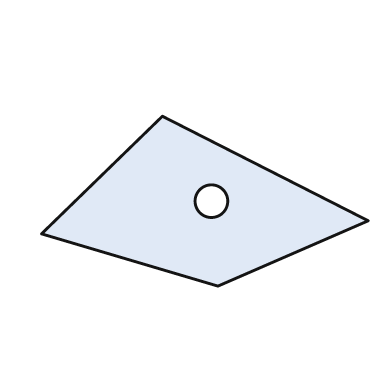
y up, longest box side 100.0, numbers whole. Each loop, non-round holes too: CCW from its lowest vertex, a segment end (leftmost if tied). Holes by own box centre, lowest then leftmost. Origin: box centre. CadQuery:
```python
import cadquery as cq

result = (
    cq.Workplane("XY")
    .moveTo(4.0, -26.0)
    .lineTo(50.0, -6.0)
    .lineTo(-13.0, 26.0)
    .lineTo(-50.0, -10.0)
    .close()
    .moveTo(2.0, 0.0)
    .circle(5.0)
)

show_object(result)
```